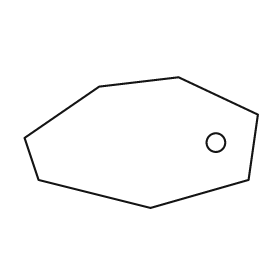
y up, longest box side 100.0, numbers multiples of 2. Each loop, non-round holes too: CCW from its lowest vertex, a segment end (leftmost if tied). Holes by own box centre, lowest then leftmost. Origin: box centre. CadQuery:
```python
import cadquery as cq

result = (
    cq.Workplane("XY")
    .moveTo(4.0, -28.0)
    .lineTo(46.0, -16.0)
    .lineTo(50.0, 12.0)
    .lineTo(16.0, 28.0)
    .lineTo(-18.0, 24.0)
    .lineTo(-50.0, 2.0)
    .lineTo(-44.0, -16.0)
    .close()
    .moveTo(32.0, 0.0)
    .circle(4.0)
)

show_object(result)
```